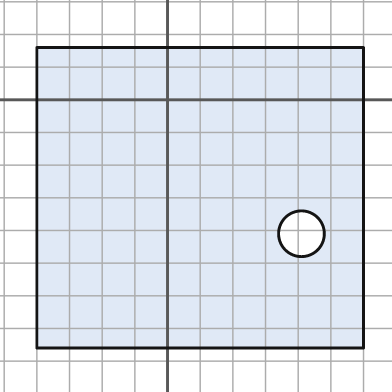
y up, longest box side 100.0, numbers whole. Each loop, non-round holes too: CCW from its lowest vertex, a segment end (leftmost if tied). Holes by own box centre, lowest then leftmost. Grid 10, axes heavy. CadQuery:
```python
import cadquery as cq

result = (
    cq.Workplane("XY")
    .moveTo(-40.0, -76.0)
    .lineTo(60.0, -76.0)
    .lineTo(60.0, 16.0)
    .lineTo(-40.0, 16.0)
    .close()
    .moveTo(41.0, -41.0)
    .circle(7.0)
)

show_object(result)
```